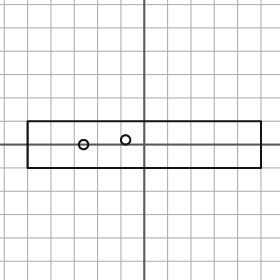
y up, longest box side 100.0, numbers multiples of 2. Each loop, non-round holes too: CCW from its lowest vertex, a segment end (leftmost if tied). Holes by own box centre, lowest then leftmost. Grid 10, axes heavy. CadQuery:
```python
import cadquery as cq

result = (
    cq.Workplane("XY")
    .moveTo(-50.0, -10.0)
    .lineTo(50.0, -10.0)
    .lineTo(50.0, 10.0)
    .lineTo(-50.0, 10.0)
    .close()
    .moveTo(-26.0, 0.0)
    .circle(2.0)
    .moveTo(-8.0, 2.0)
    .circle(2.0)
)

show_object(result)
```